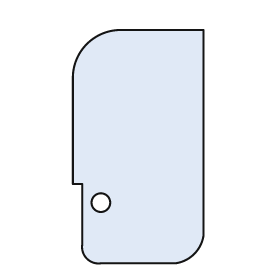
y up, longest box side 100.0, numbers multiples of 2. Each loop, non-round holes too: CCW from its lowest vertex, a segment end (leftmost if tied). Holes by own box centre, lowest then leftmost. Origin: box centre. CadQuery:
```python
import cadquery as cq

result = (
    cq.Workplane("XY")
    .moveTo(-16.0, -50.0)
    .lineTo(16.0, -50.0)
    .threePointArc((24.0, -46.0), (28.0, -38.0))
    .lineTo(28.0, 50.0)
    .lineTo(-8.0, 50.0)
    .threePointArc((-22.0, 44.0), (-28.0, 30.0))
    .lineTo(-28.0, -16.0)
    .lineTo(-24.0, -16.0)
    .lineTo(-24.0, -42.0)
    .threePointArc((-22.0, -48.0), (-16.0, -50.0))
    .close()
    .moveTo(-16.0, -24.0)
    .circle(4.0)
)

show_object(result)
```